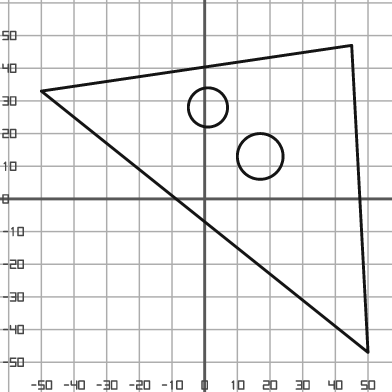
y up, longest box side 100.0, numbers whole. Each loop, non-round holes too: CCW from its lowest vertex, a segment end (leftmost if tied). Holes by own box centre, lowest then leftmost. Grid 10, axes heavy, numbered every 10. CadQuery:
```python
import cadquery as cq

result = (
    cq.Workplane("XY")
    .moveTo(50.0, -47.0)
    .lineTo(45.0, 47.0)
    .lineTo(-50.0, 33.0)
    .close()
    .moveTo(17.0, 13.0)
    .circle(7.0)
    .moveTo(1.0, 28.0)
    .circle(6.0)
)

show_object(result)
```